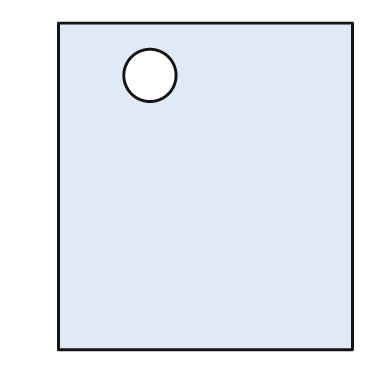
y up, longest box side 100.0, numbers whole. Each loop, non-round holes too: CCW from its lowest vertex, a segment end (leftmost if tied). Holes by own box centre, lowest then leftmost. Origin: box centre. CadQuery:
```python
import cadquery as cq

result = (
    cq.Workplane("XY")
    .moveTo(-45.0, -50.0)
    .lineTo(45.0, -50.0)
    .lineTo(45.0, 50.0)
    .lineTo(-45.0, 50.0)
    .close()
    .moveTo(-17.0, 34.0)
    .circle(8.0)
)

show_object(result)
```